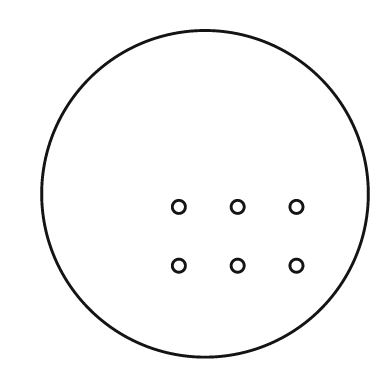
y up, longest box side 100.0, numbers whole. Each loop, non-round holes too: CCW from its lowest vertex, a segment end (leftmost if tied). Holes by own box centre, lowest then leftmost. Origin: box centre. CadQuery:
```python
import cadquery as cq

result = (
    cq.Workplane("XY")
    .moveTo(0.0, 0.0)
    .circle(50.0)
    .moveTo(-8.0, -22.0)
    .circle(2.0)
    .moveTo(10.0, -22.0)
    .circle(2.0)
    .moveTo(28.0, -22.0)
    .circle(2.0)
    .moveTo(-8.0, -4.0)
    .circle(2.0)
    .moveTo(10.0, -4.0)
    .circle(2.0)
    .moveTo(28.0, -4.0)
    .circle(2.0)
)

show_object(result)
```